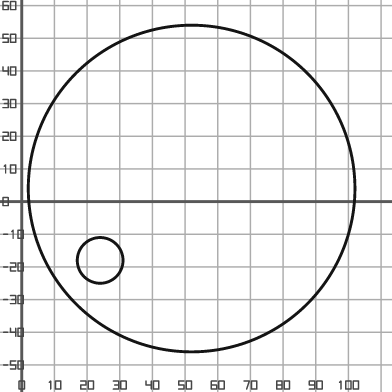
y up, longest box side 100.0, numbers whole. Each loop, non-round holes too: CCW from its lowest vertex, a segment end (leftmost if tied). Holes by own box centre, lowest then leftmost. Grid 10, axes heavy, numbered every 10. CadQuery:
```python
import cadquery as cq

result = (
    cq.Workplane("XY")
    .moveTo(52.0, 4.0)
    .circle(50.0)
    .moveTo(24.0, -18.0)
    .circle(7.0)
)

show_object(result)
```